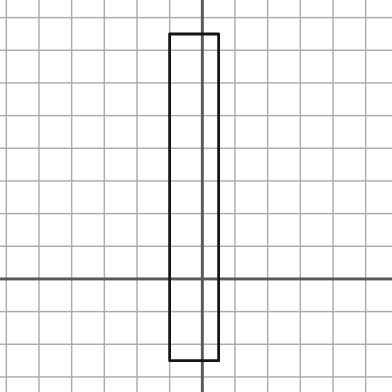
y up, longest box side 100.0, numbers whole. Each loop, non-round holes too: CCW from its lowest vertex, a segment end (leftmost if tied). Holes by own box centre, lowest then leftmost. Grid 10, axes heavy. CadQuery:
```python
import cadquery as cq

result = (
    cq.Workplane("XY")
    .moveTo(-10.0, -25.0)
    .lineTo(5.0, -25.0)
    .lineTo(5.0, 75.0)
    .lineTo(-10.0, 75.0)
    .close()
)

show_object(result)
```